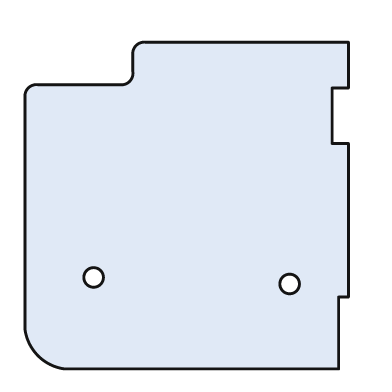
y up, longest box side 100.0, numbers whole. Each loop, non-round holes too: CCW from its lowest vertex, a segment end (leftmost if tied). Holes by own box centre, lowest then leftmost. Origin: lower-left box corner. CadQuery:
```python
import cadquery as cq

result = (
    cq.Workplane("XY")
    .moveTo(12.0, 0.0)
    .lineTo(96.0, 0.0)
    .lineTo(96.0, 22.0)
    .lineTo(99.0, 22.0)
    .lineTo(99.0, 69.0)
    .lineTo(94.0, 69.0)
    .lineTo(94.0, 86.0)
    .lineTo(99.0, 86.0)
    .lineTo(99.0, 100.0)
    .lineTo(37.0, 100.0)
    .threePointArc((34.0, 99.0), (33.0, 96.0))
    .lineTo(33.0, 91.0)
    .threePointArc((32.0, 88.0), (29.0, 87.0))
    .lineTo(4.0, 87.0)
    .threePointArc((1.0, 86.0), (0.0, 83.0))
    .lineTo(0.0, 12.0)
    .threePointArc((4.0, 4.0), (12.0, 0.0))
    .close()
    .moveTo(81.0, 26.0)
    .circle(3.0)
    .moveTo(21.0, 28.0)
    .circle(3.0)
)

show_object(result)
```